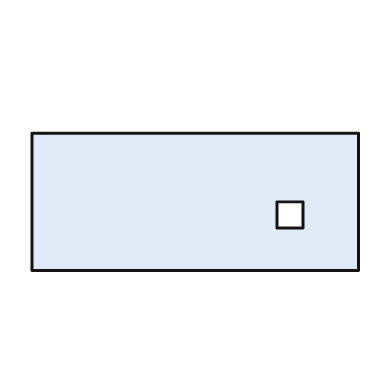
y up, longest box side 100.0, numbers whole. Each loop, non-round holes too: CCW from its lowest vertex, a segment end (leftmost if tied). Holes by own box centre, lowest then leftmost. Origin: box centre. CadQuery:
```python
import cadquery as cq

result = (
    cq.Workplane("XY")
    .moveTo(-50.0, -21.0)
    .lineTo(50.0, -21.0)
    .lineTo(50.0, 21.0)
    .lineTo(-50.0, 21.0)
    .close()
    .moveTo(25.0, -8.0)
    .lineTo(33.0, -8.0)
    .lineTo(33.0, 0.0)
    .lineTo(25.0, 0.0)
    .close()
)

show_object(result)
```